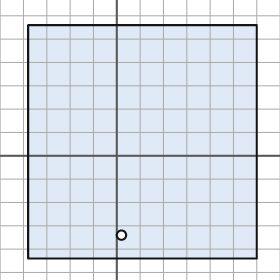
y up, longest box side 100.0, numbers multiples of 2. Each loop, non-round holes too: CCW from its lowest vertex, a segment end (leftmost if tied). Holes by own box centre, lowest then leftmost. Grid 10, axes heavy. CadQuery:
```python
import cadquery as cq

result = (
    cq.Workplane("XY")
    .moveTo(-38.0, -44.0)
    .lineTo(60.0, -44.0)
    .lineTo(60.0, 56.0)
    .lineTo(-38.0, 56.0)
    .close()
    .moveTo(2.0, -34.0)
    .circle(2.0)
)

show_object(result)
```